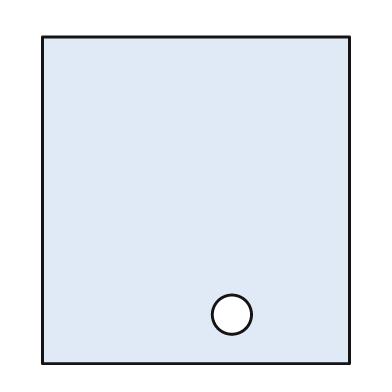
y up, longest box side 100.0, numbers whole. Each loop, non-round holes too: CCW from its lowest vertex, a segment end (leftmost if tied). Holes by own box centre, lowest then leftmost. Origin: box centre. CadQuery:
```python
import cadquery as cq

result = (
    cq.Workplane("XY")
    .moveTo(-47.0, -50.0)
    .lineTo(47.0, -50.0)
    .lineTo(47.0, 50.0)
    .lineTo(-47.0, 50.0)
    .close()
    .moveTo(11.0, -35.0)
    .circle(6.0)
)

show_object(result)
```